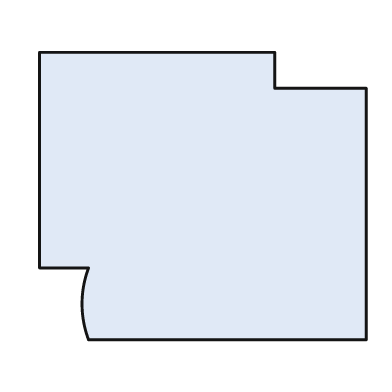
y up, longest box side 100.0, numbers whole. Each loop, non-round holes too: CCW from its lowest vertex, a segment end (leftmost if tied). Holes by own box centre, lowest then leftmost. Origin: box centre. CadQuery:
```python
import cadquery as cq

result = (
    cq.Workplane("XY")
    .moveTo(-35.0, -44.0)
    .lineTo(50.0, -44.0)
    .lineTo(50.0, 33.0)
    .lineTo(22.0, 33.0)
    .lineTo(22.0, 44.0)
    .lineTo(-50.0, 44.0)
    .lineTo(-50.0, -22.0)
    .lineTo(-35.0, -22.0)
    .threePointArc((-37.0, -33.0), (-35.0, -44.0))
    .close()
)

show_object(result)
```